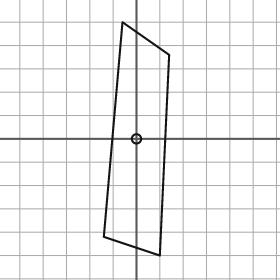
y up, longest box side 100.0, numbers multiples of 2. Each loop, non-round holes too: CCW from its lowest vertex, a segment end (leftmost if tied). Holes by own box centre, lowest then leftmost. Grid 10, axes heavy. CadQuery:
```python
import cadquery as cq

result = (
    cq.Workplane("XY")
    .moveTo(10.0, -50.0)
    .lineTo(14.0, 36.0)
    .lineTo(-6.0, 50.0)
    .lineTo(-14.0, -42.0)
    .close()
    .moveTo(0.0, 0.0)
    .circle(2.0)
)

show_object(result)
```